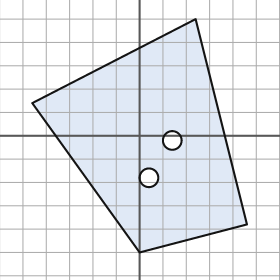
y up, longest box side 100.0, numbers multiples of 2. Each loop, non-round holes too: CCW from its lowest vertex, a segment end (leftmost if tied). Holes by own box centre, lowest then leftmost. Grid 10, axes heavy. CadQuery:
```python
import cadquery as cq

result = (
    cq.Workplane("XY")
    .moveTo(0.0, -50.0)
    .lineTo(46.0, -38.0)
    .lineTo(24.0, 50.0)
    .lineTo(-46.0, 14.0)
    .close()
    .moveTo(4.0, -18.0)
    .circle(4.0)
    .moveTo(14.0, -2.0)
    .circle(4.0)
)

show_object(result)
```